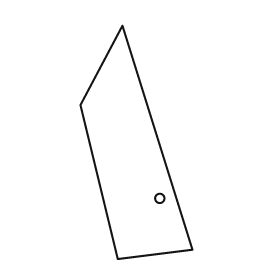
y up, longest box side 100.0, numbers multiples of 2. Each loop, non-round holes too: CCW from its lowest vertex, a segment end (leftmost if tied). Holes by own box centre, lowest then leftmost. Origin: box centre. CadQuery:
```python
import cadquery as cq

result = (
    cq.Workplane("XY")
    .moveTo(-8.0, -50.0)
    .lineTo(24.0, -46.0)
    .lineTo(-6.0, 50.0)
    .lineTo(-24.0, 16.0)
    .close()
    .moveTo(10.0, -24.0)
    .circle(2.0)
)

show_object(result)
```